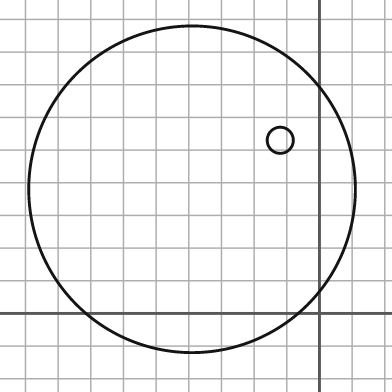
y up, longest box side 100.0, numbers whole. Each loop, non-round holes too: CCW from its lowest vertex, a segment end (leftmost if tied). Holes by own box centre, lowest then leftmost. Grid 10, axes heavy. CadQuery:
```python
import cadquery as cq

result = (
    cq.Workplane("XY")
    .moveTo(-39.0, 38.0)
    .circle(50.0)
    .moveTo(-12.0, 53.0)
    .circle(4.0)
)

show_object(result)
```